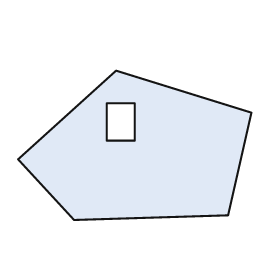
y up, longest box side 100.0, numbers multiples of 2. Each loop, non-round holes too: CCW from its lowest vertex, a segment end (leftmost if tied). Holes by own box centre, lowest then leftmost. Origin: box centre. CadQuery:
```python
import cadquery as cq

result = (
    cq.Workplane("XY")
    .moveTo(-26.0, -32.0)
    .lineTo(40.0, -30.0)
    .lineTo(50.0, 14.0)
    .lineTo(-8.0, 32.0)
    .lineTo(-50.0, -6.0)
    .close()
    .moveTo(-12.0, 2.0)
    .lineTo(0.0, 2.0)
    .lineTo(0.0, 18.0)
    .lineTo(-12.0, 18.0)
    .close()
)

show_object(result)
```